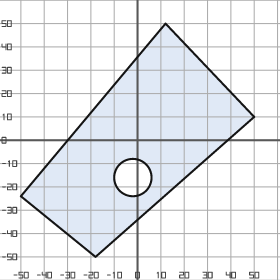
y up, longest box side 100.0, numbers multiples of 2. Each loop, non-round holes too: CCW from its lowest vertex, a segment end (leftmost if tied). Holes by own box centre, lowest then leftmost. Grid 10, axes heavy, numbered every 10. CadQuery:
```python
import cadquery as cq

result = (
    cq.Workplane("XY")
    .moveTo(-18.0, -50.0)
    .lineTo(50.0, 10.0)
    .lineTo(12.0, 50.0)
    .lineTo(-50.0, -24.0)
    .close()
    .moveTo(-2.0, -16.0)
    .circle(8.0)
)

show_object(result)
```